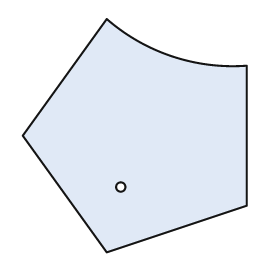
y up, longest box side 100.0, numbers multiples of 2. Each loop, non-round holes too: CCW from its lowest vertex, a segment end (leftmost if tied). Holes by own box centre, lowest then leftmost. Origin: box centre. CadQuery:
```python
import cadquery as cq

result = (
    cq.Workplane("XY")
    .moveTo(-12.0, -50.0)
    .lineTo(48.0, -30.0)
    .lineTo(48.0, 30.0)
    .threePointArc((16.0, 34.0), (-12.0, 50.0))
    .lineTo(-48.0, 0.0)
    .close()
    .moveTo(-6.0, -22.0)
    .circle(2.0)
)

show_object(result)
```